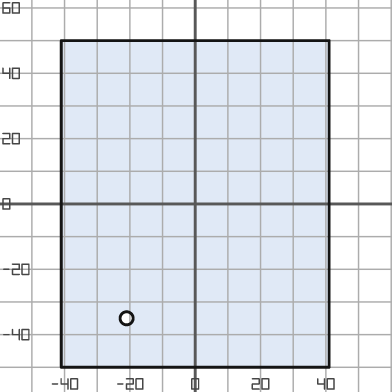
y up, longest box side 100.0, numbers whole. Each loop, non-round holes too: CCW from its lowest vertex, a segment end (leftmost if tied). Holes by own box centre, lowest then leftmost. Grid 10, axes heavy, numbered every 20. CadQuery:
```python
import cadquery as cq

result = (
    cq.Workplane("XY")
    .moveTo(-41.0, -50.0)
    .lineTo(41.0, -50.0)
    .lineTo(41.0, 50.0)
    .lineTo(-41.0, 50.0)
    .close()
    .moveTo(-21.0, -35.0)
    .circle(2.0)
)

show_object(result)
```